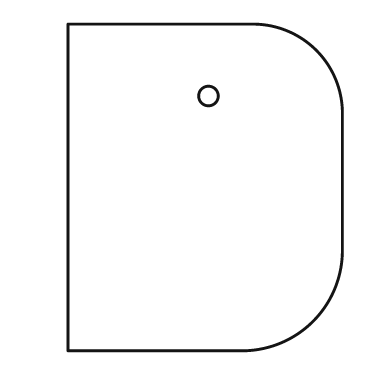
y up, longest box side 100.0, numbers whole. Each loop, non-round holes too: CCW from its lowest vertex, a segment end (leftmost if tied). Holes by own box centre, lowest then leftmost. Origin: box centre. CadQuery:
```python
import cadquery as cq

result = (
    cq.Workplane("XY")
    .moveTo(-42.0, -50.0)
    .lineTo(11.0, -50.0)
    .threePointArc((33.0, -41.0), (42.0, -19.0))
    .lineTo(42.0, 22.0)
    .threePointArc((34.0, 42.0), (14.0, 50.0))
    .lineTo(-42.0, 50.0)
    .close()
    .moveTo(1.0, 28.0)
    .circle(3.0)
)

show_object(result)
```